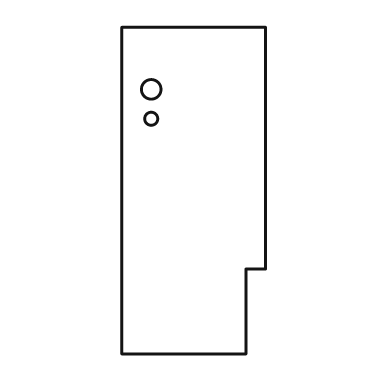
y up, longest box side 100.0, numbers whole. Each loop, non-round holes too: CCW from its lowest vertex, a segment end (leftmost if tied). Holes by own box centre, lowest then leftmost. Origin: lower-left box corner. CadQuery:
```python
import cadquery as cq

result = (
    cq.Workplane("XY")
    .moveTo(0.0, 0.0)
    .lineTo(38.0, 0.0)
    .lineTo(38.0, 26.0)
    .lineTo(44.0, 26.0)
    .lineTo(44.0, 100.0)
    .lineTo(0.0, 100.0)
    .close()
    .moveTo(9.0, 72.0)
    .circle(2.0)
    .moveTo(9.0, 81.0)
    .circle(3.0)
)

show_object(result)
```